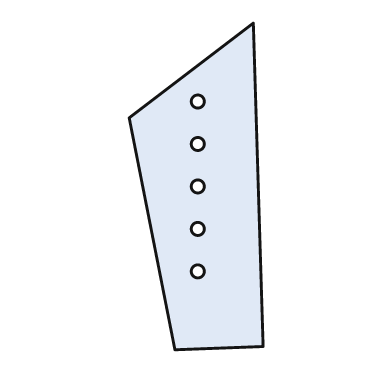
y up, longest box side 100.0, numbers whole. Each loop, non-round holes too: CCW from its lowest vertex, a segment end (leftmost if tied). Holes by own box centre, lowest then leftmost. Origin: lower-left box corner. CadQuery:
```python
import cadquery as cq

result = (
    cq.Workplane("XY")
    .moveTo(14.0, 0.0)
    .lineTo(41.0, 1.0)
    .lineTo(38.0, 100.0)
    .lineTo(0.0, 71.0)
    .close()
    .moveTo(21.0, 24.0)
    .circle(2.0)
    .moveTo(21.0, 37.0)
    .circle(2.0)
    .moveTo(21.0, 50.0)
    .circle(2.0)
    .moveTo(21.0, 63.0)
    .circle(2.0)
    .moveTo(21.0, 76.0)
    .circle(2.0)
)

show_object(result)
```